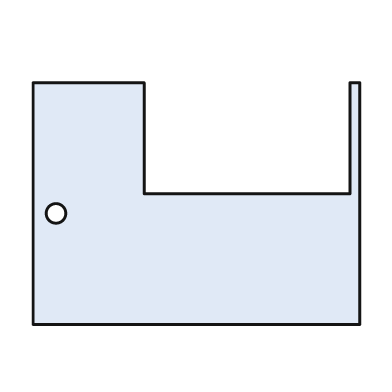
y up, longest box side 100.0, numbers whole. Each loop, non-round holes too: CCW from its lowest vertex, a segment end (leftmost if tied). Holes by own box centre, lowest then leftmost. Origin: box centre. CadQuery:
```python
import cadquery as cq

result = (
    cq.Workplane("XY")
    .moveTo(-50.0, -37.0)
    .lineTo(50.0, -37.0)
    .lineTo(50.0, 37.0)
    .lineTo(47.0, 37.0)
    .lineTo(47.0, 3.0)
    .lineTo(-16.0, 3.0)
    .lineTo(-16.0, 37.0)
    .lineTo(-50.0, 37.0)
    .close()
    .moveTo(-43.0, -3.0)
    .circle(3.0)
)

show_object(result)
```